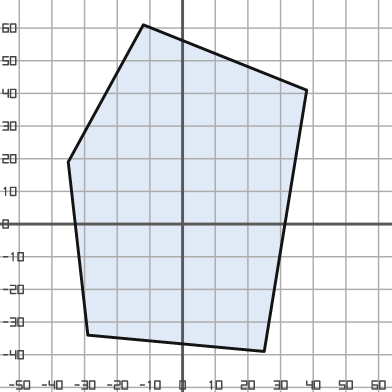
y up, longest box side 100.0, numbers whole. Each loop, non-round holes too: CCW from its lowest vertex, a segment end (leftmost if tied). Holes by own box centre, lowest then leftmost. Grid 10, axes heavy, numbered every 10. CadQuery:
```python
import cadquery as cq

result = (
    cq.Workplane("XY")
    .moveTo(25.0, -39.0)
    .lineTo(38.0, 41.0)
    .lineTo(-12.0, 61.0)
    .lineTo(-35.0, 19.0)
    .lineTo(-29.0, -34.0)
    .close()
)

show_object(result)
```